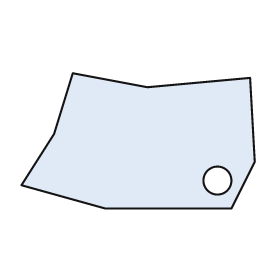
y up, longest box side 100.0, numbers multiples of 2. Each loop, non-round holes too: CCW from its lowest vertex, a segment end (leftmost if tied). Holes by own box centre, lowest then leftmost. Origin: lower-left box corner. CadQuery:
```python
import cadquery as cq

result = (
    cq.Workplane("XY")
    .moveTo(36.0, 0.0)
    .lineTo(90.0, 0.0)
    .lineTo(100.0, 20.0)
    .lineTo(98.0, 56.0)
    .lineTo(54.0, 52.0)
    .lineTo(22.0, 58.0)
    .lineTo(14.0, 32.0)
    .lineTo(0.0, 10.0)
    .close()
    .moveTo(84.0, 12.0)
    .circle(6.0)
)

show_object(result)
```